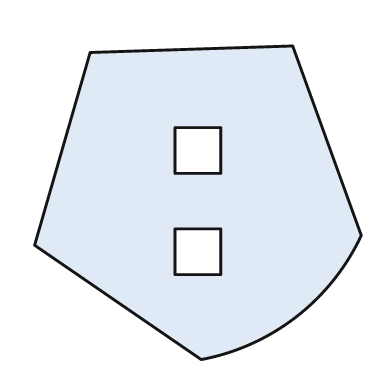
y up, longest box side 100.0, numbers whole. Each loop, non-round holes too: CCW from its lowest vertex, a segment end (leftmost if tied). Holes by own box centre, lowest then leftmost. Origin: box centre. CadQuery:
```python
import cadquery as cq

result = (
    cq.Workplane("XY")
    .moveTo(1.0, -48.0)
    .threePointArc((30.0, -35.0), (50.0, -10.0))
    .lineTo(29.0, 48.0)
    .lineTo(-33.0, 46.0)
    .lineTo(-50.0, -13.0)
    .close()
    .moveTo(-7.0, -22.0)
    .lineTo(7.0, -22.0)
    .lineTo(7.0, -8.0)
    .lineTo(-7.0, -8.0)
    .close()
    .moveTo(-7.0, 9.0)
    .lineTo(7.0, 9.0)
    .lineTo(7.0, 23.0)
    .lineTo(-7.0, 23.0)
    .close()
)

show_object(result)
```